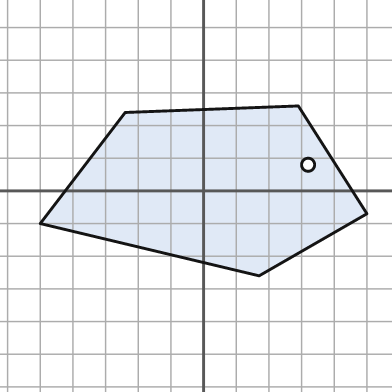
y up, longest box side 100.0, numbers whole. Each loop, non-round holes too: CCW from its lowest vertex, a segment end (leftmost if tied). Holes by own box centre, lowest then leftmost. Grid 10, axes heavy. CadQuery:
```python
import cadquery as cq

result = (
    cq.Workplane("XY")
    .moveTo(17.0, -26.0)
    .lineTo(50.0, -7.0)
    .lineTo(29.0, 26.0)
    .lineTo(-24.0, 24.0)
    .lineTo(-50.0, -10.0)
    .close()
    .moveTo(32.0, 8.0)
    .circle(2.0)
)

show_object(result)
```